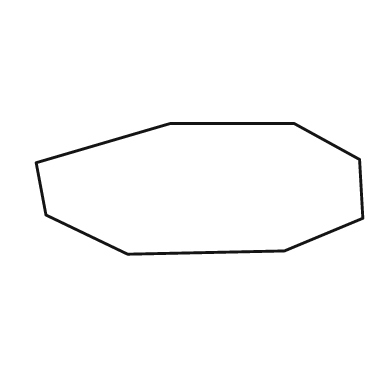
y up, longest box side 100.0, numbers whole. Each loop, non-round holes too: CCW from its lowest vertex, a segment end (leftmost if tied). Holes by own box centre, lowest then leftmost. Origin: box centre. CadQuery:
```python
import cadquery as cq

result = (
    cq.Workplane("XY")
    .moveTo(-22.0, -20.0)
    .lineTo(26.0, -19.0)
    .lineTo(50.0, -9.0)
    .lineTo(49.0, 9.0)
    .lineTo(29.0, 20.0)
    .lineTo(-9.0, 20.0)
    .lineTo(-50.0, 8.0)
    .lineTo(-47.0, -8.0)
    .close()
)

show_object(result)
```